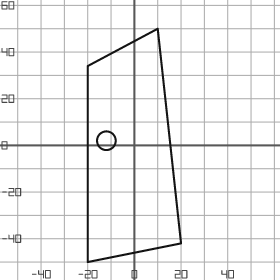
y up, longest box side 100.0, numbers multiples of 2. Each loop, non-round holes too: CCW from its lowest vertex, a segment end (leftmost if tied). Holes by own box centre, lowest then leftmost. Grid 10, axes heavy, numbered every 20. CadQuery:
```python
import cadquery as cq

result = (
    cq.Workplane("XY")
    .moveTo(-20.0, -50.0)
    .lineTo(20.0, -42.0)
    .lineTo(10.0, 50.0)
    .lineTo(-20.0, 34.0)
    .close()
    .moveTo(-12.0, 2.0)
    .circle(4.0)
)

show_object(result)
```